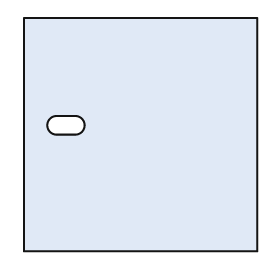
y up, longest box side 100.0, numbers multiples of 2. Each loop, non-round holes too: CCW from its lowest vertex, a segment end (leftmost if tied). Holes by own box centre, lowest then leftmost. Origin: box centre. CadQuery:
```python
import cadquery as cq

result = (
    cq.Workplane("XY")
    .moveTo(-50.0, -50.0)
    .lineTo(50.0, -50.0)
    .lineTo(50.0, 50.0)
    .lineTo(-50.0, 50.0)
    .close()
    .moveTo(-36.0, 0.0)
    .lineTo(-28.0, 0.0)
    .threePointArc((-24.0, 4.0), (-28.0, 8.0))
    .lineTo(-36.0, 8.0)
    .threePointArc((-40.0, 4.0), (-36.0, 0.0))
    .close()
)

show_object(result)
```